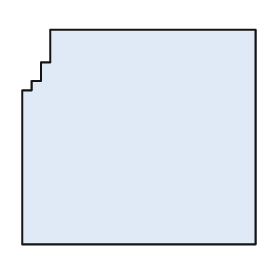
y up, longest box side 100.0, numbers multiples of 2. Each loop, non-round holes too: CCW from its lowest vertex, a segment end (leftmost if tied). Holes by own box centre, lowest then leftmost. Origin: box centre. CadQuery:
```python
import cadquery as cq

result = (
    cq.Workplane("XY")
    .moveTo(-50.0, -46.0)
    .lineTo(50.0, -46.0)
    .lineTo(50.0, 46.0)
    .lineTo(-38.0, 46.0)
    .lineTo(-38.0, 32.0)
    .lineTo(-42.0, 32.0)
    .lineTo(-42.0, 24.0)
    .lineTo(-46.0, 24.0)
    .lineTo(-46.0, 20.0)
    .lineTo(-50.0, 20.0)
    .close()
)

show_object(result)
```